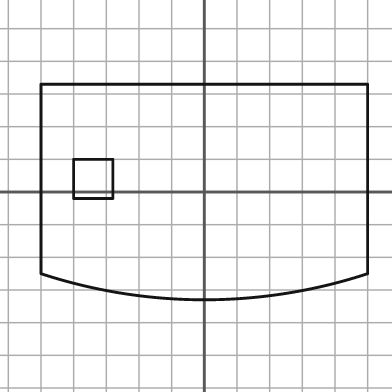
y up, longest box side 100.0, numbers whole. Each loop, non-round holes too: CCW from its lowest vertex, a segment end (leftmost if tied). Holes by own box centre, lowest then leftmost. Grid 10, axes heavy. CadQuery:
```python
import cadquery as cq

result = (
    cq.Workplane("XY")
    .moveTo(-50.0, -25.0)
    .threePointArc((0.0, -33.0), (50.0, -25.0))
    .lineTo(50.0, 33.0)
    .lineTo(-50.0, 33.0)
    .close()
    .moveTo(-40.0, -2.0)
    .lineTo(-28.0, -2.0)
    .lineTo(-28.0, 10.0)
    .lineTo(-40.0, 10.0)
    .close()
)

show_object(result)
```